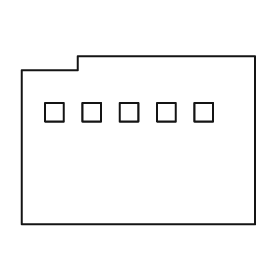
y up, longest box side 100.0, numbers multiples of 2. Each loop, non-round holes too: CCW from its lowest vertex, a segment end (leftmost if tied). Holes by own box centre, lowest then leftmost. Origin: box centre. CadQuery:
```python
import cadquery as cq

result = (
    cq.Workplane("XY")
    .moveTo(-50.0, -36.0)
    .lineTo(50.0, -36.0)
    .lineTo(50.0, 36.0)
    .lineTo(-26.0, 36.0)
    .lineTo(-26.0, 30.0)
    .lineTo(-50.0, 30.0)
    .close()
    .moveTo(-40.0, 8.0)
    .lineTo(-32.0, 8.0)
    .lineTo(-32.0, 16.0)
    .lineTo(-40.0, 16.0)
    .close()
    .moveTo(-24.0, 8.0)
    .lineTo(-16.0, 8.0)
    .lineTo(-16.0, 16.0)
    .lineTo(-24.0, 16.0)
    .close()
    .moveTo(-8.0, 8.0)
    .lineTo(0.0, 8.0)
    .lineTo(0.0, 16.0)
    .lineTo(-8.0, 16.0)
    .close()
    .moveTo(8.0, 8.0)
    .lineTo(16.0, 8.0)
    .lineTo(16.0, 16.0)
    .lineTo(8.0, 16.0)
    .close()
    .moveTo(24.0, 8.0)
    .lineTo(32.0, 8.0)
    .lineTo(32.0, 16.0)
    .lineTo(24.0, 16.0)
    .close()
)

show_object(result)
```